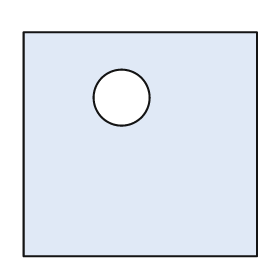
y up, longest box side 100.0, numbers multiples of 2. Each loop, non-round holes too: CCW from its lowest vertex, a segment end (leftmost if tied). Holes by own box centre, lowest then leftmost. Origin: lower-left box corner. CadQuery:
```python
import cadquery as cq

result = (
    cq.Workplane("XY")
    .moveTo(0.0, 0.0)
    .lineTo(100.0, 0.0)
    .lineTo(100.0, 96.0)
    .lineTo(0.0, 96.0)
    .close()
    .moveTo(42.0, 68.0)
    .circle(12.0)
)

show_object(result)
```